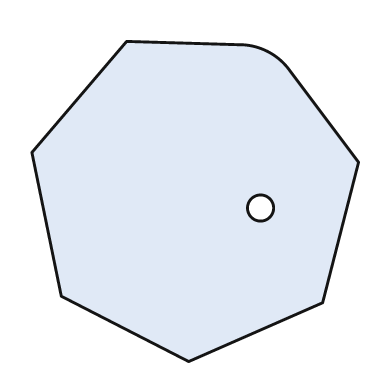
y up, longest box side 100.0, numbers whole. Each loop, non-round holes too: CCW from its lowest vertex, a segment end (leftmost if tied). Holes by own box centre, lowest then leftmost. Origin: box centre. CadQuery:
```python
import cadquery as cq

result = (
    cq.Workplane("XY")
    .moveTo(-2.0, -49.0)
    .lineTo(39.0, -31.0)
    .lineTo(50.0, 12.0)
    .lineTo(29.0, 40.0)
    .threePointArc((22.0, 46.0), (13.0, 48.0))
    .lineTo(-21.0, 49.0)
    .lineTo(-50.0, 15.0)
    .lineTo(-41.0, -29.0)
    .close()
    .moveTo(20.0, -2.0)
    .circle(4.0)
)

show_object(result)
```